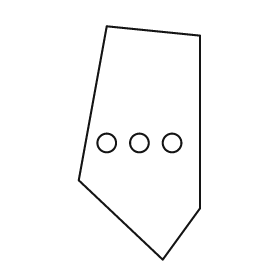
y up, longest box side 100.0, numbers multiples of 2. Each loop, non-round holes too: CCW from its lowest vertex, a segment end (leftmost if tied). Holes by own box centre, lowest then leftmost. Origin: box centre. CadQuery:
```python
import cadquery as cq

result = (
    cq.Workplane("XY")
    .moveTo(10.0, -50.0)
    .lineTo(26.0, -28.0)
    .lineTo(26.0, 46.0)
    .lineTo(-14.0, 50.0)
    .lineTo(-26.0, -16.0)
    .close()
    .moveTo(-14.0, 0.0)
    .circle(4.0)
    .moveTo(0.0, 0.0)
    .circle(4.0)
    .moveTo(14.0, 0.0)
    .circle(4.0)
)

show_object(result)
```